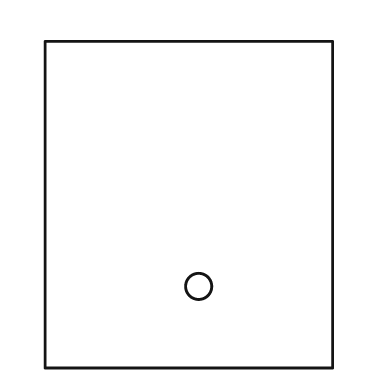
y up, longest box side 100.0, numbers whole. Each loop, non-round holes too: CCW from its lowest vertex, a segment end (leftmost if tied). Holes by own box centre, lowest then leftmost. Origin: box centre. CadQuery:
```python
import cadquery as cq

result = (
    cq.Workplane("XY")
    .moveTo(-44.0, -50.0)
    .lineTo(44.0, -50.0)
    .lineTo(44.0, 50.0)
    .lineTo(-44.0, 50.0)
    .close()
    .moveTo(3.0, -25.0)
    .circle(4.0)
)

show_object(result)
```